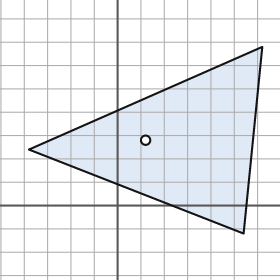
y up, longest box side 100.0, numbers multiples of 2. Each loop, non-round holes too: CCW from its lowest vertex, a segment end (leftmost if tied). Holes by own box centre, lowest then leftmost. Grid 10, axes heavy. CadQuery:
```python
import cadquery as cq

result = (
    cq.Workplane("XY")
    .moveTo(54.0, -12.0)
    .lineTo(62.0, 68.0)
    .lineTo(-38.0, 24.0)
    .close()
    .moveTo(12.0, 28.0)
    .circle(2.0)
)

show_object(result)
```